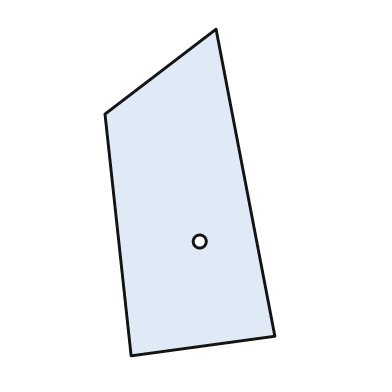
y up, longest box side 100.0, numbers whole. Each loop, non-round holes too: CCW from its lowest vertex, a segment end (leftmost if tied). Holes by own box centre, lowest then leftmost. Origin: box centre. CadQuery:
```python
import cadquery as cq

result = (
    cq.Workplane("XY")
    .moveTo(-18.0, -50.0)
    .lineTo(26.0, -44.0)
    .lineTo(8.0, 50.0)
    .lineTo(-26.0, 24.0)
    .close()
    .moveTo(3.0, -15.0)
    .circle(2.0)
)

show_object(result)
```